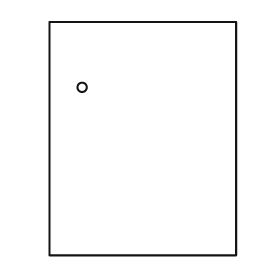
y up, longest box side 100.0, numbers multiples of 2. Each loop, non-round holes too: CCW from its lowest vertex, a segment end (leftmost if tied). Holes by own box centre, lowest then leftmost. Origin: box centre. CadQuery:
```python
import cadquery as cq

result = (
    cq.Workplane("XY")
    .moveTo(-40.0, -50.0)
    .lineTo(40.0, -50.0)
    .lineTo(40.0, 50.0)
    .lineTo(-40.0, 50.0)
    .close()
    .moveTo(-26.0, 22.0)
    .circle(2.0)
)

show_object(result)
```